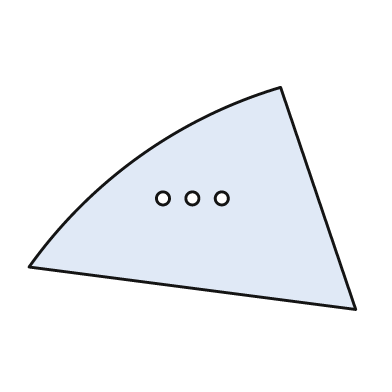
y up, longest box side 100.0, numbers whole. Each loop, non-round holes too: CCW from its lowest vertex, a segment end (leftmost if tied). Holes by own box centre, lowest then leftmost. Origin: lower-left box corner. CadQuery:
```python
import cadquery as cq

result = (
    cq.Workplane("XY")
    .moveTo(100.0, 0.0)
    .lineTo(77.0, 68.0)
    .threePointArc((34.0, 47.0), (0.0, 13.0))
    .close()
    .moveTo(41.0, 34.0)
    .circle(2.0)
    .moveTo(50.0, 34.0)
    .circle(2.0)
    .moveTo(59.0, 34.0)
    .circle(2.0)
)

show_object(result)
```